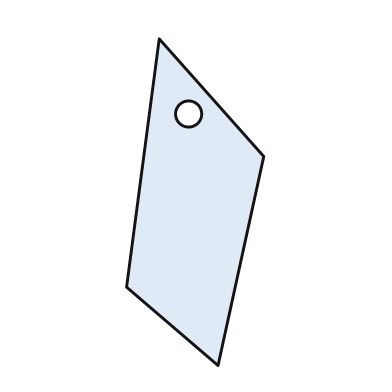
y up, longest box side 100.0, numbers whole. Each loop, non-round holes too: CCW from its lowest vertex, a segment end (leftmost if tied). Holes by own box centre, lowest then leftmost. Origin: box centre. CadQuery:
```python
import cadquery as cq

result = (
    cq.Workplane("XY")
    .moveTo(7.0, -50.0)
    .lineTo(21.0, 14.0)
    .lineTo(-11.0, 50.0)
    .lineTo(-21.0, -26.0)
    .close()
    .moveTo(-2.0, 27.0)
    .circle(4.0)
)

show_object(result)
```